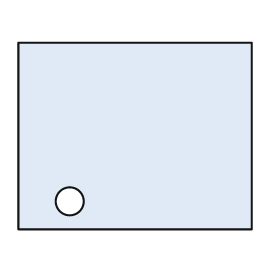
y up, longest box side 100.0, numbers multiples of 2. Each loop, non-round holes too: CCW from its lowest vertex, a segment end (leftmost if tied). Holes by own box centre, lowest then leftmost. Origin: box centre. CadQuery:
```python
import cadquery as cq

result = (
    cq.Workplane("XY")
    .moveTo(-50.0, -40.0)
    .lineTo(50.0, -40.0)
    .lineTo(50.0, 40.0)
    .lineTo(-50.0, 40.0)
    .close()
    .moveTo(-28.0, -28.0)
    .circle(6.0)
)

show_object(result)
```